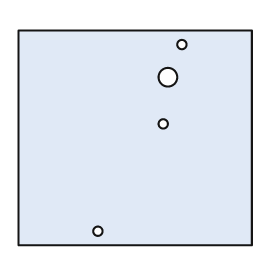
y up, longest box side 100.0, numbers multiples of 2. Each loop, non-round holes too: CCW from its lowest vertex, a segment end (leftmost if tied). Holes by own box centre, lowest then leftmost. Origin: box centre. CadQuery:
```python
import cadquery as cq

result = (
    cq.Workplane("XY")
    .moveTo(-50.0, -46.0)
    .lineTo(50.0, -46.0)
    .lineTo(50.0, 46.0)
    .lineTo(-50.0, 46.0)
    .close()
    .moveTo(-16.0, -40.0)
    .circle(2.0)
    .moveTo(12.0, 6.0)
    .circle(2.0)
    .moveTo(14.0, 26.0)
    .circle(4.0)
    .moveTo(20.0, 40.0)
    .circle(2.0)
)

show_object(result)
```